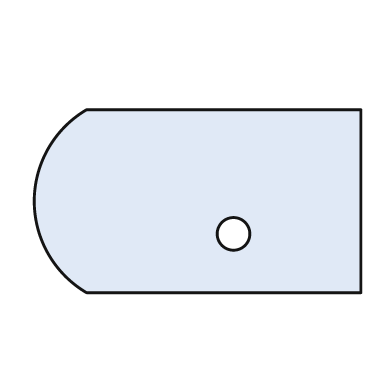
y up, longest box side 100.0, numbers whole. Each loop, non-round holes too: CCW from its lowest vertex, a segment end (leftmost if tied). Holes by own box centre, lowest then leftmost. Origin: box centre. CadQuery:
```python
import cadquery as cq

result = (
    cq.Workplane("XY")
    .moveTo(-34.0, -28.0)
    .lineTo(50.0, -28.0)
    .lineTo(50.0, 28.0)
    .lineTo(-34.0, 28.0)
    .threePointArc((-50.0, 0.0), (-34.0, -28.0))
    .close()
    .moveTo(11.0, -10.0)
    .circle(5.0)
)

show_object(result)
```